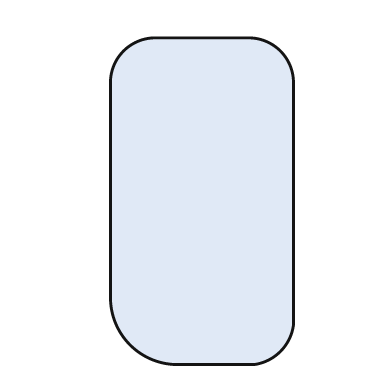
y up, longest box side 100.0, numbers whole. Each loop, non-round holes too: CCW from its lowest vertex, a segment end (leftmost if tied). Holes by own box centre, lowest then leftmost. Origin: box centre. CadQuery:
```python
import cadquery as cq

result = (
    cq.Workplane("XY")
    .moveTo(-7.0, -50.0)
    .lineTo(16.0, -50.0)
    .threePointArc((24.0, -46.0), (28.0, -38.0))
    .lineTo(28.0, 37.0)
    .threePointArc((24.0, 46.0), (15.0, 50.0))
    .lineTo(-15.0, 50.0)
    .threePointArc((-24.0, 46.0), (-28.0, 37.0))
    .lineTo(-28.0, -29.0)
    .threePointArc((-22.0, -44.0), (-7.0, -50.0))
    .close()
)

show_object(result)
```